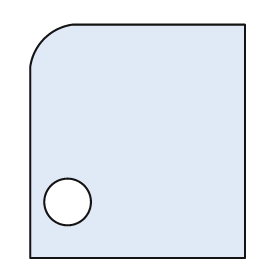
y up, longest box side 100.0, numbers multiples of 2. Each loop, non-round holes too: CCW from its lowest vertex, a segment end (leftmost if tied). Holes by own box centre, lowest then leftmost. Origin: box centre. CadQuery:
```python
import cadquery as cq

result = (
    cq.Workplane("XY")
    .moveTo(-46.0, -50.0)
    .lineTo(46.0, -50.0)
    .lineTo(46.0, 50.0)
    .lineTo(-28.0, 50.0)
    .threePointArc((-40.0, 44.0), (-46.0, 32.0))
    .close()
    .moveTo(-30.0, -26.0)
    .circle(10.0)
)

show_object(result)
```